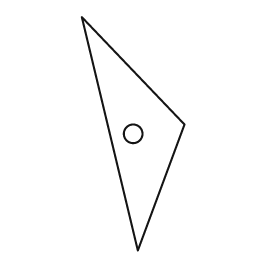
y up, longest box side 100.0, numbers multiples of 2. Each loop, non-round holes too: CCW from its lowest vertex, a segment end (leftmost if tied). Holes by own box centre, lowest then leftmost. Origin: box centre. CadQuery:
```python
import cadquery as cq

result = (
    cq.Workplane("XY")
    .moveTo(2.0, -50.0)
    .lineTo(22.0, 4.0)
    .lineTo(-22.0, 50.0)
    .close()
    .moveTo(0.0, 0.0)
    .circle(4.0)
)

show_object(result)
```